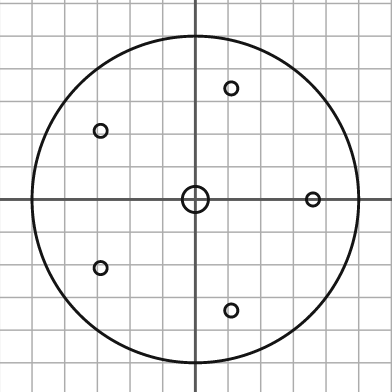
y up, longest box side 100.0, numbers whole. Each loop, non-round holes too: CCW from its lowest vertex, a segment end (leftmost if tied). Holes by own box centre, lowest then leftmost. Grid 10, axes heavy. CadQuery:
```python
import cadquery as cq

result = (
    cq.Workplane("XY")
    .moveTo(0.0, 0.0)
    .circle(50.0)
    .moveTo(11.0, -34.0)
    .circle(2.0)
    .moveTo(-29.0, -21.0)
    .circle(2.0)
    .moveTo(0.0, 0.0)
    .circle(4.0)
    .moveTo(36.0, 0.0)
    .circle(2.0)
    .moveTo(-29.0, 21.0)
    .circle(2.0)
    .moveTo(11.0, 34.0)
    .circle(2.0)
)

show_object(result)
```